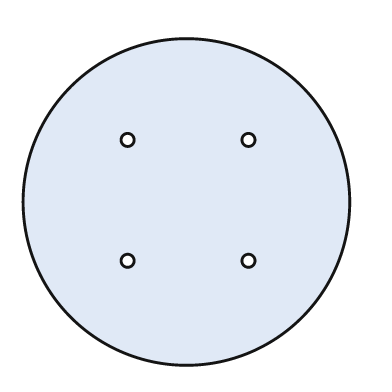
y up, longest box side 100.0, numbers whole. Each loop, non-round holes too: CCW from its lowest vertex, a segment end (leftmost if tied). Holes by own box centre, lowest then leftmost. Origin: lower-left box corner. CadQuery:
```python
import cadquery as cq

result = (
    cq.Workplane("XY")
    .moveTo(50.0, 50.0)
    .circle(50.0)
    .moveTo(32.0, 32.0)
    .circle(2.0)
    .moveTo(69.0, 32.0)
    .circle(2.0)
    .moveTo(32.0, 69.0)
    .circle(2.0)
    .moveTo(69.0, 69.0)
    .circle(2.0)
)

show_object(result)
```